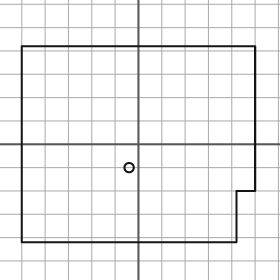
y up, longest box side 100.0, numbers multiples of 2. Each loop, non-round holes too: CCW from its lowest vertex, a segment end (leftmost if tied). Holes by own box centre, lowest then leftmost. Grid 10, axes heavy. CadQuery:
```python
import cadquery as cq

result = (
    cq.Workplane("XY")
    .moveTo(-50.0, -42.0)
    .lineTo(42.0, -42.0)
    .lineTo(42.0, -20.0)
    .lineTo(50.0, -20.0)
    .lineTo(50.0, 42.0)
    .lineTo(-50.0, 42.0)
    .close()
    .moveTo(-4.0, -10.0)
    .circle(2.0)
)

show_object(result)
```